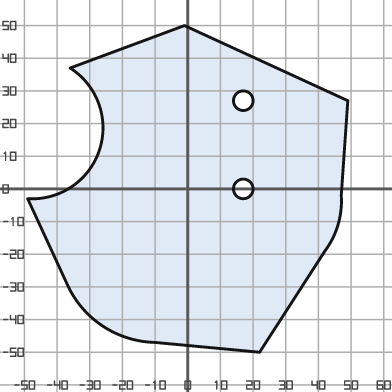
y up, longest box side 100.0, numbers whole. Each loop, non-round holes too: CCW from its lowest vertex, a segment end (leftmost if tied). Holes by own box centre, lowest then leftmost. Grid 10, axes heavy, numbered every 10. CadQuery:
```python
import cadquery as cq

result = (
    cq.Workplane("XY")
    .moveTo(22.0, -50.0)
    .lineTo(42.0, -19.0)
    .threePointArc((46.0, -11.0), (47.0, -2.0))
    .lineTo(49.0, 27.0)
    .lineTo(-1.0, 50.0)
    .lineTo(-36.0, 37.0)
    .threePointArc((-27.0, 12.0), (-49.0, -3.0))
    .lineTo(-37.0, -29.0)
    .threePointArc((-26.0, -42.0), (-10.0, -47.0))
    .close()
    .moveTo(17.0, 0.0)
    .circle(3.0)
    .moveTo(17.0, 27.0)
    .circle(3.0)
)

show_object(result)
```